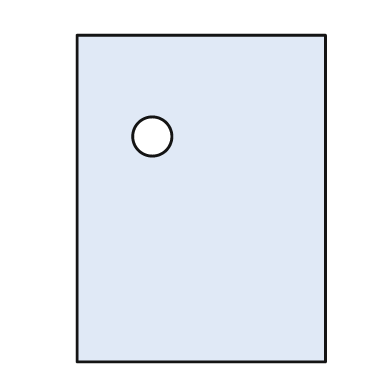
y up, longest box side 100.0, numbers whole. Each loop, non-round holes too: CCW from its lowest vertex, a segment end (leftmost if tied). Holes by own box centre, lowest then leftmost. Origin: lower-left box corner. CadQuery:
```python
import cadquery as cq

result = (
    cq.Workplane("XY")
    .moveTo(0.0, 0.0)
    .lineTo(76.0, 0.0)
    .lineTo(76.0, 100.0)
    .lineTo(0.0, 100.0)
    .close()
    .moveTo(23.0, 69.0)
    .circle(6.0)
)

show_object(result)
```